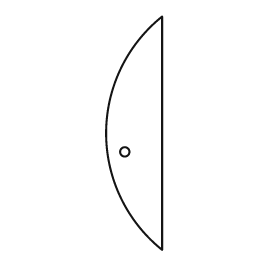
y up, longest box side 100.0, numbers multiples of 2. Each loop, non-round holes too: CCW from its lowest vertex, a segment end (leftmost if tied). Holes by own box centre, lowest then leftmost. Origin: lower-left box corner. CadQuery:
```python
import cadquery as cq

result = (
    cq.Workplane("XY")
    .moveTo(24.0, 0.0)
    .lineTo(24.0, 100.0)
    .threePointArc((0.0, 50.0), (24.0, 0.0))
    .close()
    .moveTo(8.0, 42.0)
    .circle(2.0)
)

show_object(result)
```